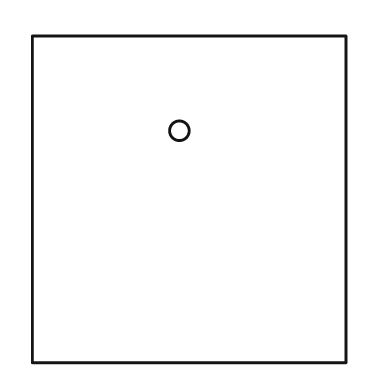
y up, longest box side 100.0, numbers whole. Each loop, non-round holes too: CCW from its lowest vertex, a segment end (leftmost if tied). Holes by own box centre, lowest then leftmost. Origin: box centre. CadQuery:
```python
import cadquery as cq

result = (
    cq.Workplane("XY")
    .moveTo(-48.0, -50.0)
    .lineTo(48.0, -50.0)
    .lineTo(48.0, 50.0)
    .lineTo(-48.0, 50.0)
    .close()
    .moveTo(-3.0, 21.0)
    .circle(3.0)
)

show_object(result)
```